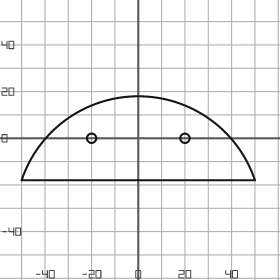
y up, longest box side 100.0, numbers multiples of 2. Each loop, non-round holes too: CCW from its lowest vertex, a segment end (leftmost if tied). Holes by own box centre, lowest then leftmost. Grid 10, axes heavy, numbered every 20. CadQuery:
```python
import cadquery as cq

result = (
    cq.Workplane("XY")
    .moveTo(-50.0, -18.0)
    .lineTo(50.0, -18.0)
    .threePointArc((0.0, 18.0), (-50.0, -18.0))
    .close()
    .moveTo(-20.0, 0.0)
    .circle(2.0)
    .moveTo(20.0, 0.0)
    .circle(2.0)
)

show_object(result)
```